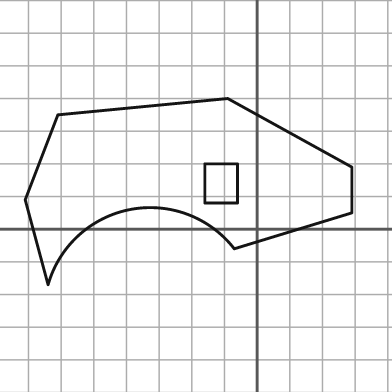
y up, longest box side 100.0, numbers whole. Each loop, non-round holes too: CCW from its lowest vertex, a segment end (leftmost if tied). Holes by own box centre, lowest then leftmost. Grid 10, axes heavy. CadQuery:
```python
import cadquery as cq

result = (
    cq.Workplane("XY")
    .moveTo(-64.0, -17.0)
    .threePointArc((-39.0, 6.0), (-7.0, -6.0))
    .lineTo(29.0, 5.0)
    .lineTo(29.0, 19.0)
    .lineTo(-9.0, 40.0)
    .lineTo(-61.0, 35.0)
    .lineTo(-71.0, 9.0)
    .close()
    .moveTo(-16.0, 8.0)
    .lineTo(-6.0, 8.0)
    .lineTo(-6.0, 20.0)
    .lineTo(-16.0, 20.0)
    .close()
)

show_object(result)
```